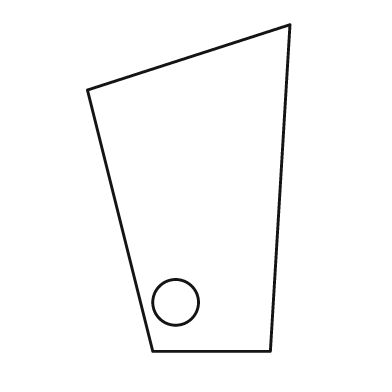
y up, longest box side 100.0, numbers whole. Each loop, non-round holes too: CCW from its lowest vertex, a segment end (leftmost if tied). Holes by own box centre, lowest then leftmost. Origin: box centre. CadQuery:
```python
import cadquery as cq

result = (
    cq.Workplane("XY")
    .moveTo(-11.0, -50.0)
    .lineTo(25.0, -50.0)
    .lineTo(31.0, 50.0)
    .lineTo(-31.0, 30.0)
    .close()
    .moveTo(-4.0, -35.0)
    .circle(7.0)
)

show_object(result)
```